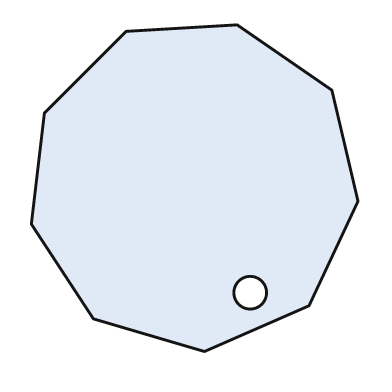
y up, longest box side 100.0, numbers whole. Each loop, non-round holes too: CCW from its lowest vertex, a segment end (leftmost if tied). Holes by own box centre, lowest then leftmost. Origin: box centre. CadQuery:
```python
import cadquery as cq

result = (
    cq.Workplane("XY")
    .moveTo(3.0, -50.0)
    .lineTo(35.0, -36.0)
    .lineTo(50.0, -4.0)
    .lineTo(42.0, 30.0)
    .lineTo(13.0, 50.0)
    .lineTo(-21.0, 48.0)
    .lineTo(-46.0, 23.0)
    .lineTo(-50.0, -11.0)
    .lineTo(-31.0, -40.0)
    .close()
    .moveTo(17.0, -32.0)
    .circle(5.0)
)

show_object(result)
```